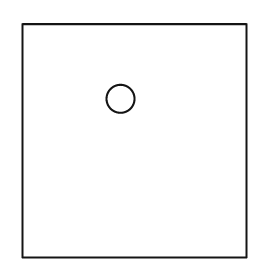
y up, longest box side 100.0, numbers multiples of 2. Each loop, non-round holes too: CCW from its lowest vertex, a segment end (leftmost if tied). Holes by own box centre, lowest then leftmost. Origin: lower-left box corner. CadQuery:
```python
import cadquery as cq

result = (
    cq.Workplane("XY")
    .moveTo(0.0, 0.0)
    .lineTo(96.0, 0.0)
    .lineTo(96.0, 100.0)
    .lineTo(0.0, 100.0)
    .close()
    .moveTo(42.0, 68.0)
    .circle(6.0)
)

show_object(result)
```